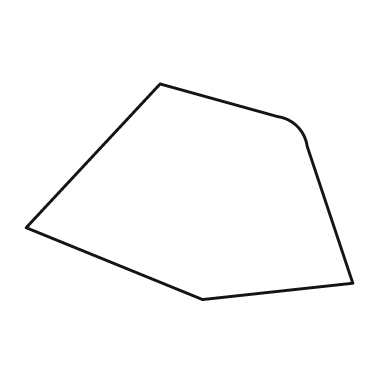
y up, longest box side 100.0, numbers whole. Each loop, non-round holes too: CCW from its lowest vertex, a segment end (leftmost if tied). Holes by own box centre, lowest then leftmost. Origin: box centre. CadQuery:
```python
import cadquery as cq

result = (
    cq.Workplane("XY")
    .moveTo(4.0, -33.0)
    .lineTo(50.0, -28.0)
    .lineTo(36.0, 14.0)
    .threePointArc((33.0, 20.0), (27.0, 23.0))
    .lineTo(-9.0, 33.0)
    .lineTo(-50.0, -11.0)
    .close()
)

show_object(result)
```